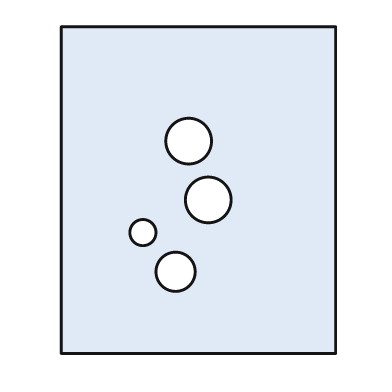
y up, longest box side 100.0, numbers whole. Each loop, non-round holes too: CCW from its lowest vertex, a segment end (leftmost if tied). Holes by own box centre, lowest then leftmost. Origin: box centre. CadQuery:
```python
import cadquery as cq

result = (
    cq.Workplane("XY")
    .moveTo(-42.0, -50.0)
    .lineTo(42.0, -50.0)
    .lineTo(42.0, 50.0)
    .lineTo(-42.0, 50.0)
    .close()
    .moveTo(-7.0, -25.0)
    .circle(6.0)
    .moveTo(-17.0, -13.0)
    .circle(4.0)
    .moveTo(3.0, -3.0)
    .circle(7.0)
    .moveTo(-3.0, 15.0)
    .circle(7.0)
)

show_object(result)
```